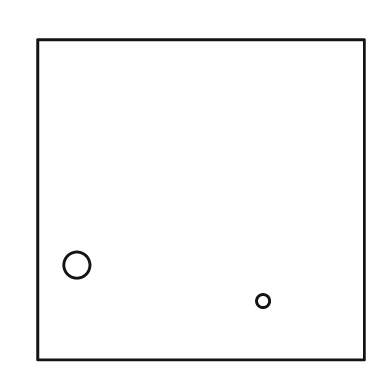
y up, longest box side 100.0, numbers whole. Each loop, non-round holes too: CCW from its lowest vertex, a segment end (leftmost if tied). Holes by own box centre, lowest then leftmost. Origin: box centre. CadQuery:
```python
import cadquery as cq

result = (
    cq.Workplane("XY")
    .moveTo(-50.0, -49.0)
    .lineTo(50.0, -49.0)
    .lineTo(50.0, 49.0)
    .lineTo(-50.0, 49.0)
    .close()
    .moveTo(19.0, -31.0)
    .circle(2.0)
    .moveTo(-38.0, -20.0)
    .circle(4.0)
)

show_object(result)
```